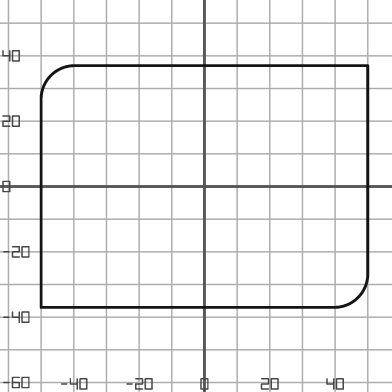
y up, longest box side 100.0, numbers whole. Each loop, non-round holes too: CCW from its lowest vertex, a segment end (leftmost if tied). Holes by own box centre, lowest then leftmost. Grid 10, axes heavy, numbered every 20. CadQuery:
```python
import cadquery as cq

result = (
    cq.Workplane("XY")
    .moveTo(-50.0, -37.0)
    .lineTo(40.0, -37.0)
    .threePointArc((47.0, -34.0), (50.0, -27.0))
    .lineTo(50.0, 37.0)
    .lineTo(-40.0, 37.0)
    .threePointArc((-47.0, 34.0), (-50.0, 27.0))
    .close()
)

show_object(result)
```